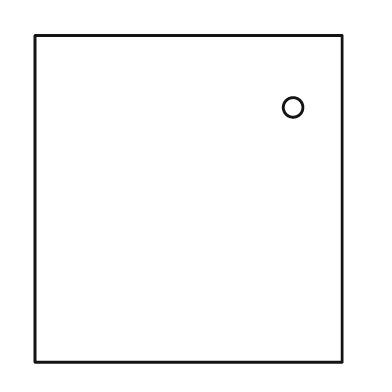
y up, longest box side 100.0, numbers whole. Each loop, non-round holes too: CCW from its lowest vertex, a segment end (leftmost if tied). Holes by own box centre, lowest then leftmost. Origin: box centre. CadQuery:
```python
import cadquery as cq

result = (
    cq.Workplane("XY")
    .moveTo(-47.0, -50.0)
    .lineTo(47.0, -50.0)
    .lineTo(47.0, 50.0)
    .lineTo(-47.0, 50.0)
    .close()
    .moveTo(32.0, 28.0)
    .circle(3.0)
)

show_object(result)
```